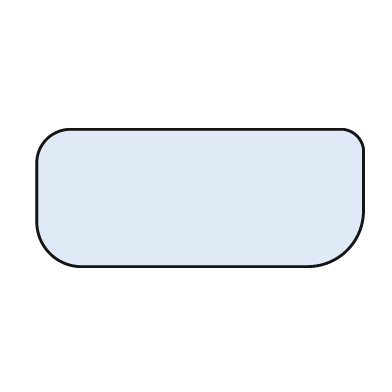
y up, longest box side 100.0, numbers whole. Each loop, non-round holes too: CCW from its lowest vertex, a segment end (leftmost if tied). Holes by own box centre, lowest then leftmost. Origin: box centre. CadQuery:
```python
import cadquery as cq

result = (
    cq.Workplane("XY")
    .moveTo(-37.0, -21.0)
    .lineTo(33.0, -21.0)
    .threePointArc((45.0, -16.0), (50.0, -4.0))
    .lineTo(50.0, 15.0)
    .threePointArc((48.0, 19.0), (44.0, 21.0))
    .lineTo(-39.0, 21.0)
    .threePointArc((-47.0, 18.0), (-50.0, 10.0))
    .lineTo(-50.0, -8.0)
    .threePointArc((-46.0, -17.0), (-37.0, -21.0))
    .close()
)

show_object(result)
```